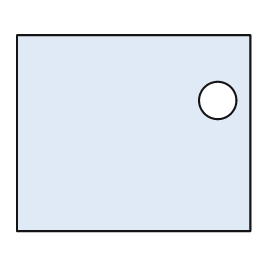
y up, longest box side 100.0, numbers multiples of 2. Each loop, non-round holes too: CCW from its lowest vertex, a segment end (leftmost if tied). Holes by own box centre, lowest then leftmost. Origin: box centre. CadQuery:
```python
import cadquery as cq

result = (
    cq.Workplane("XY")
    .moveTo(-50.0, -42.0)
    .lineTo(50.0, -42.0)
    .lineTo(50.0, 42.0)
    .lineTo(-50.0, 42.0)
    .close()
    .moveTo(36.0, 14.0)
    .circle(8.0)
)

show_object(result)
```